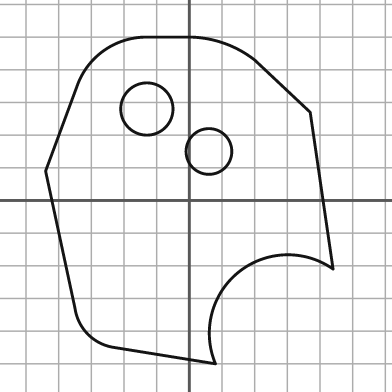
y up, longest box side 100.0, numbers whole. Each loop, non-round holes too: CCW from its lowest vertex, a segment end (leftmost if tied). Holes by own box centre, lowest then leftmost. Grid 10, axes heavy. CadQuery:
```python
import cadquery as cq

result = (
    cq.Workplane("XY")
    .moveTo(8.0, -50.0)
    .threePointArc((15.0, -22.0), (44.0, -21.0))
    .lineTo(37.0, 27.0)
    .lineTo(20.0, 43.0)
    .threePointArc((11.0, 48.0), (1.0, 50.0))
    .lineTo(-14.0, 50.0)
    .threePointArc((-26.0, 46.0), (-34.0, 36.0))
    .lineTo(-44.0, 9.0)
    .lineTo(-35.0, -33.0)
    .threePointArc((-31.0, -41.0), (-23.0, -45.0))
    .close()
    .moveTo(6.0, 15.0)
    .circle(7.0)
    .moveTo(-13.0, 28.0)
    .circle(8.0)
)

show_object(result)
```